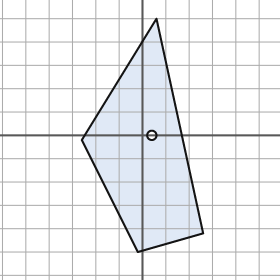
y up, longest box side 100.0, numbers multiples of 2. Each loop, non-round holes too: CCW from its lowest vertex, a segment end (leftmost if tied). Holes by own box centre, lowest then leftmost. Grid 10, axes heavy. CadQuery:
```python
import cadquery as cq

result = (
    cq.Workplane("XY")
    .moveTo(-2.0, -50.0)
    .lineTo(26.0, -42.0)
    .lineTo(6.0, 50.0)
    .lineTo(-26.0, -2.0)
    .close()
    .moveTo(4.0, 0.0)
    .circle(2.0)
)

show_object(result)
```